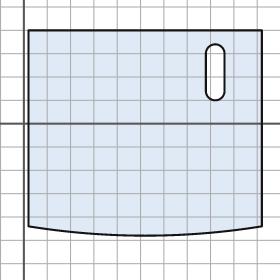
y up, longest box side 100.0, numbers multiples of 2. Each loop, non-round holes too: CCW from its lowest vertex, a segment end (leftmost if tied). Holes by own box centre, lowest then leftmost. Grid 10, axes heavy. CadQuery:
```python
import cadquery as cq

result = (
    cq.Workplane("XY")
    .moveTo(2.0, -44.0)
    .threePointArc((52.0, -48.0), (102.0, -44.0))
    .lineTo(102.0, 40.0)
    .lineTo(2.0, 40.0)
    .close()
    .moveTo(78.0, 14.0)
    .threePointArc((82.0, 10.0), (86.0, 14.0))
    .lineTo(86.0, 30.0)
    .threePointArc((82.0, 34.0), (78.0, 30.0))
    .close()
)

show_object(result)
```